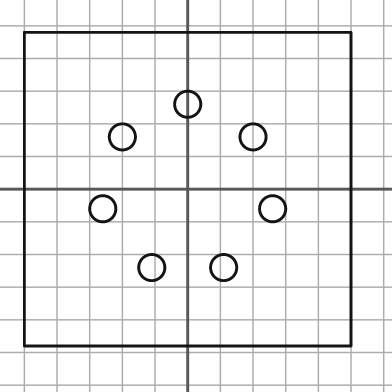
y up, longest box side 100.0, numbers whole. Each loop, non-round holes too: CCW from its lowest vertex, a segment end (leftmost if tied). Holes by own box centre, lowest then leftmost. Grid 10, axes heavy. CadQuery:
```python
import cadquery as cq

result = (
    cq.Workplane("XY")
    .moveTo(-50.0, -48.0)
    .lineTo(50.0, -48.0)
    .lineTo(50.0, 48.0)
    .lineTo(-50.0, 48.0)
    .close()
    .moveTo(-11.0, -24.0)
    .circle(4.0)
    .moveTo(11.0, -24.0)
    .circle(4.0)
    .moveTo(-26.0, -6.0)
    .circle(4.0)
    .moveTo(26.0, -6.0)
    .circle(4.0)
    .moveTo(-20.0, 16.0)
    .circle(4.0)
    .moveTo(20.0, 16.0)
    .circle(4.0)
    .moveTo(0.0, 26.0)
    .circle(4.0)
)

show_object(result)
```